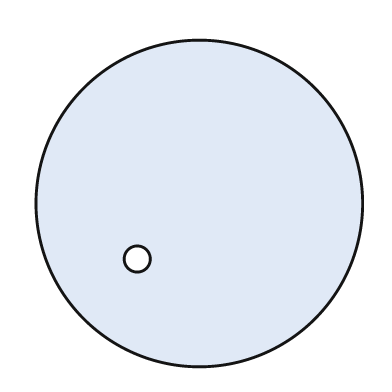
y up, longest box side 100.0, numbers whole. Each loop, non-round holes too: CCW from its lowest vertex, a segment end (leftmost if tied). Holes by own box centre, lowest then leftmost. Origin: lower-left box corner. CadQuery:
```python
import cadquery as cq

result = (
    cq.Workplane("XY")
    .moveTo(50.0, 50.0)
    .circle(50.0)
    .moveTo(31.0, 33.0)
    .circle(4.0)
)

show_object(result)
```